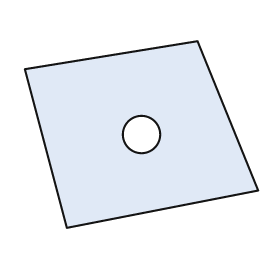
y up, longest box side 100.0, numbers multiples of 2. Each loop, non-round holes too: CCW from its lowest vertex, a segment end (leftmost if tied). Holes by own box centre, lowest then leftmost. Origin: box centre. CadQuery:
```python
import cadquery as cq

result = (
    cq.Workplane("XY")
    .moveTo(-32.0, -40.0)
    .lineTo(50.0, -24.0)
    .lineTo(24.0, 40.0)
    .lineTo(-50.0, 28.0)
    .close()
    .moveTo(0.0, 0.0)
    .circle(8.0)
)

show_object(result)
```